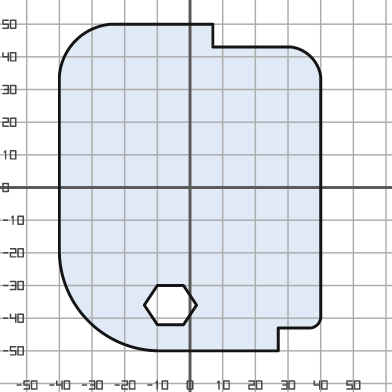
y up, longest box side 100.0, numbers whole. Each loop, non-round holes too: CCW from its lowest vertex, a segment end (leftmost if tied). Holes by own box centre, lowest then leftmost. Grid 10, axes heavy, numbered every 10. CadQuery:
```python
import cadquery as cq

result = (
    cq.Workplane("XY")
    .moveTo(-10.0, -50.0)
    .lineTo(27.0, -50.0)
    .lineTo(27.0, -43.0)
    .lineTo(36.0, -43.0)
    .threePointArc((39.0, -42.0), (40.0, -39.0))
    .lineTo(40.0, 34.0)
    .threePointArc((37.0, 40.0), (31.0, 43.0))
    .lineTo(7.0, 43.0)
    .lineTo(7.0, 50.0)
    .lineTo(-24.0, 50.0)
    .threePointArc((-35.0, 45.0), (-40.0, 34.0))
    .lineTo(-40.0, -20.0)
    .threePointArc((-31.0, -41.0), (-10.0, -50.0))
    .close()
    .moveTo(-10.0, -42.0)
    .lineTo(-2.0, -42.0)
    .lineTo(2.0, -36.0)
    .lineTo(-2.0, -30.0)
    .lineTo(-10.0, -30.0)
    .lineTo(-14.0, -36.0)
    .close()
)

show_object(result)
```